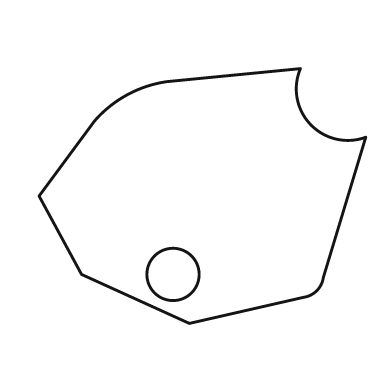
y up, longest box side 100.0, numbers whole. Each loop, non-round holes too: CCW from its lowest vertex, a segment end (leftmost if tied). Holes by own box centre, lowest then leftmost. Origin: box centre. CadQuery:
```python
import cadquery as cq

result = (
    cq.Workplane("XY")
    .moveTo(-4.0, -39.0)
    .lineTo(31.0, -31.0)
    .threePointArc((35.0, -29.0), (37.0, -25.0))
    .lineTo(50.0, 18.0)
    .threePointArc((33.0, 22.0), (30.0, 39.0))
    .lineTo(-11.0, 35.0)
    .threePointArc((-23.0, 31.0), (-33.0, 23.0))
    .lineTo(-50.0, 0.0)
    .lineTo(-37.0, -24.0)
    .close()
    .moveTo(-9.0, -24.0)
    .circle(8.0)
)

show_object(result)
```